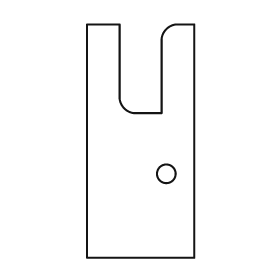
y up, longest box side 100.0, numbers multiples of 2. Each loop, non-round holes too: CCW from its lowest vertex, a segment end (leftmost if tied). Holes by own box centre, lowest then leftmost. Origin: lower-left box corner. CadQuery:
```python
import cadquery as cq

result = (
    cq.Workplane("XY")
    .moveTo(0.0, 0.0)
    .lineTo(46.0, 0.0)
    .lineTo(46.0, 100.0)
    .lineTo(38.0, 100.0)
    .threePointArc((34.0, 98.0), (32.0, 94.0))
    .lineTo(32.0, 62.0)
    .lineTo(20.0, 62.0)
    .threePointArc((16.0, 64.0), (14.0, 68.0))
    .lineTo(14.0, 100.0)
    .lineTo(0.0, 100.0)
    .close()
    .moveTo(34.0, 36.0)
    .circle(4.0)
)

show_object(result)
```